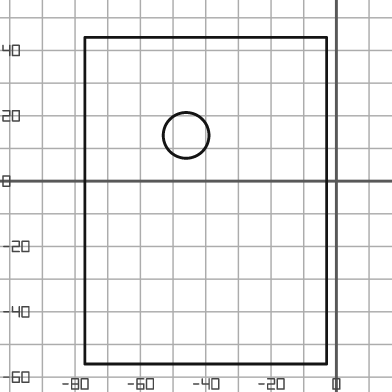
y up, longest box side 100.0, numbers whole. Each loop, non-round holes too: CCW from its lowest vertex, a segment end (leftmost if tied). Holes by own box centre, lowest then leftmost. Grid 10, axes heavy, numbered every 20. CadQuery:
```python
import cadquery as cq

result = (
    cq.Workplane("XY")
    .moveTo(-77.0, -56.0)
    .lineTo(-3.0, -56.0)
    .lineTo(-3.0, 44.0)
    .lineTo(-77.0, 44.0)
    .close()
    .moveTo(-46.0, 14.0)
    .circle(7.0)
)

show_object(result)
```